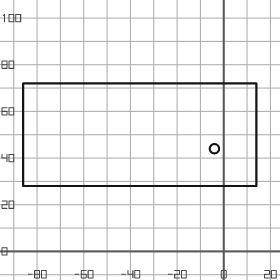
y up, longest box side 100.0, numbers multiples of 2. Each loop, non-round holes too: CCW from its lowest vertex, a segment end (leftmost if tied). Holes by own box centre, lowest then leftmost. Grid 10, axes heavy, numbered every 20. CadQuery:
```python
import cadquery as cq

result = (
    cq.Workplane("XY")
    .moveTo(-86.0, 28.0)
    .lineTo(14.0, 28.0)
    .lineTo(14.0, 72.0)
    .lineTo(-86.0, 72.0)
    .close()
    .moveTo(-4.0, 44.0)
    .circle(2.0)
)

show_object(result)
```